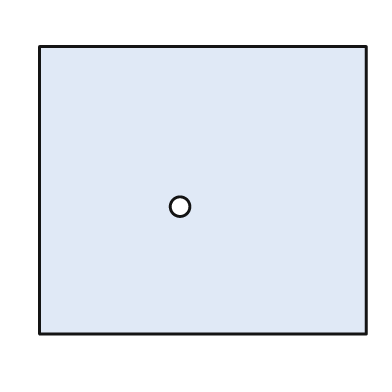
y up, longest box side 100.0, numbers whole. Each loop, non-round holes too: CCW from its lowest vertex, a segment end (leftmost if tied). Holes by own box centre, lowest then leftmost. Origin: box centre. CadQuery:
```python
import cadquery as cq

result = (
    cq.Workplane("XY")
    .moveTo(-50.0, -44.0)
    .lineTo(50.0, -44.0)
    .lineTo(50.0, 44.0)
    .lineTo(-50.0, 44.0)
    .close()
    .moveTo(-7.0, -5.0)
    .circle(3.0)
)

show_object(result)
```